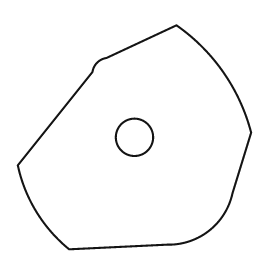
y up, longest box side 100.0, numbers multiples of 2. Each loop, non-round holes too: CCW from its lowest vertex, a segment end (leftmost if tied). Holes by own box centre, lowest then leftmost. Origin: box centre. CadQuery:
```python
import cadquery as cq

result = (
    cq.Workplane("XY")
    .moveTo(-28.0, -48.0)
    .lineTo(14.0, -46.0)
    .threePointArc((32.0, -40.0), (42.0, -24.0))
    .lineTo(50.0, 2.0)
    .threePointArc((38.0, 28.0), (18.0, 48.0))
    .lineTo(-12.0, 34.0)
    .threePointArc((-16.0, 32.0), (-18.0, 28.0))
    .lineTo(-50.0, -12.0)
    .threePointArc((-42.0, -32.0), (-28.0, -48.0))
    .close()
    .moveTo(0.0, 0.0)
    .circle(8.0)
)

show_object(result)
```